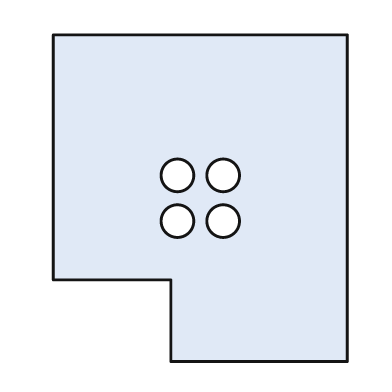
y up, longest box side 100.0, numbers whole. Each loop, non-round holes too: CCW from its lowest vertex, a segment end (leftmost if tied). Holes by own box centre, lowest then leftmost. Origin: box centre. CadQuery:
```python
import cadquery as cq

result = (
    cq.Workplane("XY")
    .moveTo(-9.0, -50.0)
    .lineTo(45.0, -50.0)
    .lineTo(45.0, 50.0)
    .lineTo(-45.0, 50.0)
    .lineTo(-45.0, -25.0)
    .lineTo(-9.0, -25.0)
    .close()
    .moveTo(-7.0, -7.0)
    .circle(5.0)
    .moveTo(7.0, -7.0)
    .circle(5.0)
    .moveTo(-7.0, 7.0)
    .circle(5.0)
    .moveTo(7.0, 7.0)
    .circle(5.0)
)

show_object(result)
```